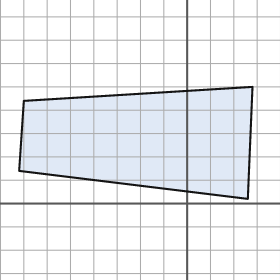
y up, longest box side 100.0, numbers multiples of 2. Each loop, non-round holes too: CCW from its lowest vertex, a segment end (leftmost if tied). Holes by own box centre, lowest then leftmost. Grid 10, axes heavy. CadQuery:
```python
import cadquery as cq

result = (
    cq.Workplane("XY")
    .moveTo(26.0, 2.0)
    .lineTo(28.0, 50.0)
    .lineTo(-70.0, 44.0)
    .lineTo(-72.0, 14.0)
    .close()
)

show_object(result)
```